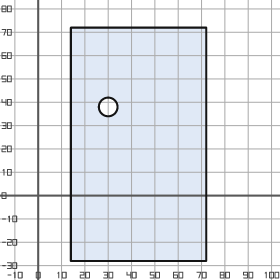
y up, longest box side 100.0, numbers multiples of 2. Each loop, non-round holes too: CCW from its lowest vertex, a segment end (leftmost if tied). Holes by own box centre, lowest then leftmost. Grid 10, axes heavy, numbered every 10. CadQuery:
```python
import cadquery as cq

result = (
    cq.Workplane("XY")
    .moveTo(14.0, -28.0)
    .lineTo(72.0, -28.0)
    .lineTo(72.0, 72.0)
    .lineTo(14.0, 72.0)
    .close()
    .moveTo(30.0, 38.0)
    .circle(4.0)
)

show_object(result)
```